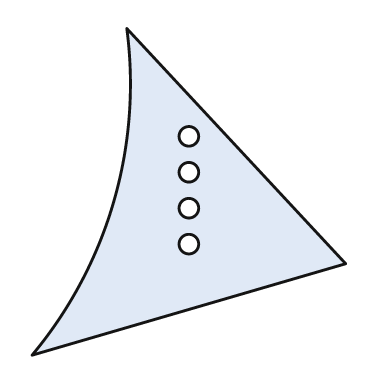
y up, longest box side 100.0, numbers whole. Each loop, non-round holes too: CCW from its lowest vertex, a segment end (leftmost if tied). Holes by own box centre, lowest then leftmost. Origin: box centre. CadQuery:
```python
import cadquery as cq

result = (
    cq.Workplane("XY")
    .moveTo(-48.0, -50.0)
    .lineTo(48.0, -22.0)
    .lineTo(-19.0, 50.0)
    .threePointArc((-23.0, -3.0), (-48.0, -50.0))
    .close()
    .moveTo(0.0, -16.0)
    .circle(3.0)
    .moveTo(0.0, -5.0)
    .circle(3.0)
    .moveTo(0.0, 6.0)
    .circle(3.0)
    .moveTo(0.0, 17.0)
    .circle(3.0)
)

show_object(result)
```